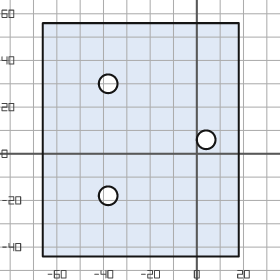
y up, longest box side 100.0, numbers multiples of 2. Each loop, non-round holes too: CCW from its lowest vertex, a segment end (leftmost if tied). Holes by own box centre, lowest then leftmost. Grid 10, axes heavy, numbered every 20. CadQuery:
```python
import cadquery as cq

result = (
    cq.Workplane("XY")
    .moveTo(-66.0, -44.0)
    .lineTo(18.0, -44.0)
    .lineTo(18.0, 56.0)
    .lineTo(-66.0, 56.0)
    .close()
    .moveTo(-38.0, -18.0)
    .circle(4.0)
    .moveTo(4.0, 6.0)
    .circle(4.0)
    .moveTo(-38.0, 30.0)
    .circle(4.0)
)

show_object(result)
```